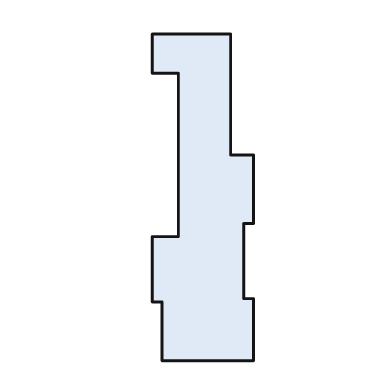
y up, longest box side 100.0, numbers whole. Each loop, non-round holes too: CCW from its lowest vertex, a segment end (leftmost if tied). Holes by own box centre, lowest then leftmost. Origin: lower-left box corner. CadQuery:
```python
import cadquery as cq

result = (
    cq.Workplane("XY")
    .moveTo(3.0, 0.0)
    .lineTo(31.0, 0.0)
    .lineTo(31.0, 19.0)
    .lineTo(28.0, 19.0)
    .lineTo(28.0, 42.0)
    .lineTo(31.0, 42.0)
    .lineTo(31.0, 63.0)
    .lineTo(24.0, 63.0)
    .lineTo(24.0, 100.0)
    .lineTo(0.0, 100.0)
    .lineTo(0.0, 88.0)
    .lineTo(8.0, 88.0)
    .lineTo(8.0, 38.0)
    .lineTo(0.0, 38.0)
    .lineTo(0.0, 18.0)
    .lineTo(3.0, 18.0)
    .close()
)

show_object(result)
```